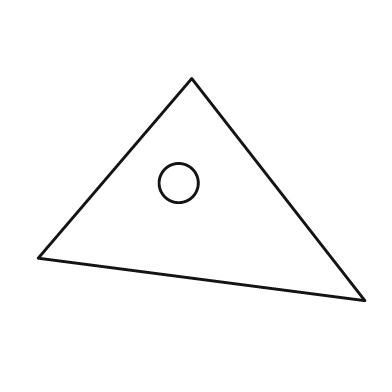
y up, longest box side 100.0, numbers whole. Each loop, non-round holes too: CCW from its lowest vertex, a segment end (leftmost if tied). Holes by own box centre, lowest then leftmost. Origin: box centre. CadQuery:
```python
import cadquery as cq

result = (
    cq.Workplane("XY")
    .moveTo(50.0, -34.0)
    .lineTo(-3.0, 34.0)
    .lineTo(-50.0, -21.0)
    .close()
    .moveTo(-7.0, 2.0)
    .circle(6.0)
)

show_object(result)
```